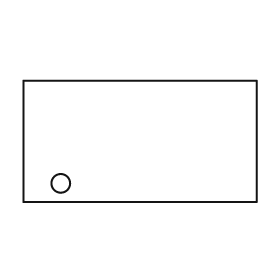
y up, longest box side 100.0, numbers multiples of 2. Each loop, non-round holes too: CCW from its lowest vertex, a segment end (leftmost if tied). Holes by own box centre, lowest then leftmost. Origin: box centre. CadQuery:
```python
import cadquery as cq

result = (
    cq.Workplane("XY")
    .moveTo(-50.0, -26.0)
    .lineTo(50.0, -26.0)
    .lineTo(50.0, 26.0)
    .lineTo(-50.0, 26.0)
    .close()
    .moveTo(-34.0, -18.0)
    .circle(4.0)
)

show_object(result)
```